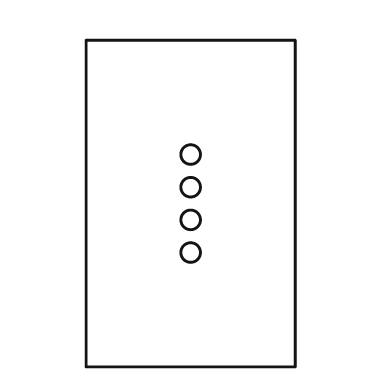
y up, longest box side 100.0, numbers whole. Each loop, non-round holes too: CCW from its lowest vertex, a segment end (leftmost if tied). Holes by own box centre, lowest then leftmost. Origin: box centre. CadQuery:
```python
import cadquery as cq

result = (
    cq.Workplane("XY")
    .moveTo(-32.0, -50.0)
    .lineTo(32.0, -50.0)
    .lineTo(32.0, 50.0)
    .lineTo(-32.0, 50.0)
    .close()
    .moveTo(0.0, -15.0)
    .circle(3.0)
    .moveTo(0.0, -5.0)
    .circle(3.0)
    .moveTo(0.0, 5.0)
    .circle(3.0)
    .moveTo(0.0, 15.0)
    .circle(3.0)
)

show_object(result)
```